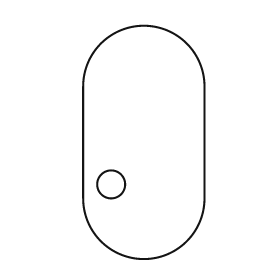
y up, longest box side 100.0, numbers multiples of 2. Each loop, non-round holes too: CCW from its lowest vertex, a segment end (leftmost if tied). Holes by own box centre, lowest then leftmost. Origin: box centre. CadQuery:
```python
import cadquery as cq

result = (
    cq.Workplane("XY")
    .moveTo(-26.0, -24.0)
    .threePointArc((0.0, -50.0), (26.0, -24.0))
    .lineTo(26.0, 24.0)
    .threePointArc((0.0, 50.0), (-26.0, 24.0))
    .close()
    .moveTo(-14.0, -18.0)
    .circle(6.0)
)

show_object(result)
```